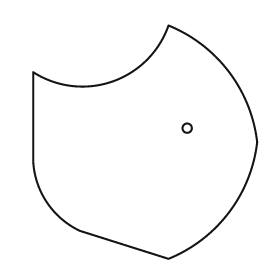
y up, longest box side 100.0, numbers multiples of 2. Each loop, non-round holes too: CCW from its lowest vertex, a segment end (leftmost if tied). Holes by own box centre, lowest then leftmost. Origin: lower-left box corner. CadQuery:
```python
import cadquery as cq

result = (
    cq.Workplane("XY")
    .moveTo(58.0, 0.0)
    .threePointArc((84.0, 20.0), (96.0, 50.0))
    .threePointArc((84.0, 80.0), (58.0, 100.0))
    .threePointArc((34.0, 76.0), (0.0, 80.0))
    .lineTo(0.0, 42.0)
    .threePointArc((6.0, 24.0), (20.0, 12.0))
    .close()
    .moveTo(66.0, 56.0)
    .circle(2.0)
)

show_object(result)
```